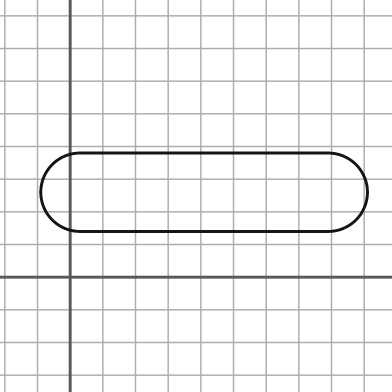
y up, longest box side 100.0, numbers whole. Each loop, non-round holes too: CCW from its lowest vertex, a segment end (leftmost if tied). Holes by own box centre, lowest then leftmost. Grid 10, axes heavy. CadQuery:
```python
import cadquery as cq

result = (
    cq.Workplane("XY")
    .moveTo(3.0, 14.0)
    .lineTo(79.0, 14.0)
    .threePointArc((91.0, 26.0), (79.0, 38.0))
    .lineTo(3.0, 38.0)
    .threePointArc((-9.0, 26.0), (3.0, 14.0))
    .close()
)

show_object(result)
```